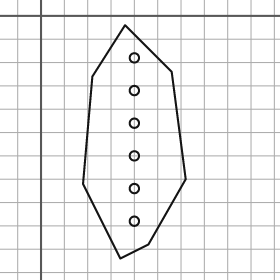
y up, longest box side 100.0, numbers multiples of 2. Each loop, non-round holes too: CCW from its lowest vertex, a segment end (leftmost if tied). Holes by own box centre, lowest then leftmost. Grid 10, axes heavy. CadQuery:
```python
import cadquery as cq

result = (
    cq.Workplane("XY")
    .moveTo(34.0, -104.0)
    .lineTo(46.0, -98.0)
    .lineTo(62.0, -70.0)
    .lineTo(56.0, -24.0)
    .lineTo(36.0, -4.0)
    .lineTo(22.0, -26.0)
    .lineTo(18.0, -72.0)
    .close()
    .moveTo(40.0, -88.0)
    .circle(2.0)
    .moveTo(40.0, -74.0)
    .circle(2.0)
    .moveTo(40.0, -60.0)
    .circle(2.0)
    .moveTo(40.0, -46.0)
    .circle(2.0)
    .moveTo(40.0, -32.0)
    .circle(2.0)
    .moveTo(40.0, -18.0)
    .circle(2.0)
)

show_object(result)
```